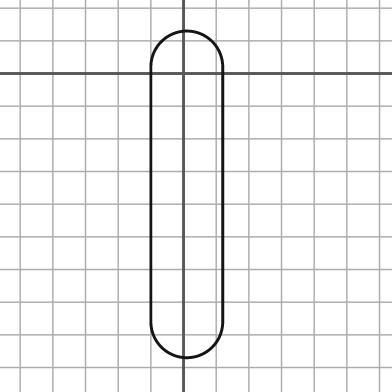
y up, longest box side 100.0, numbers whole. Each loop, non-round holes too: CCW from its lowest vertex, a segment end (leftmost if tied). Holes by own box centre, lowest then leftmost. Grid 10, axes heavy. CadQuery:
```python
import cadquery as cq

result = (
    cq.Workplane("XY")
    .moveTo(-10.0, -76.0)
    .threePointArc((1.0, -87.0), (12.0, -76.0))
    .lineTo(12.0, 2.0)
    .threePointArc((1.0, 13.0), (-10.0, 2.0))
    .close()
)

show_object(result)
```